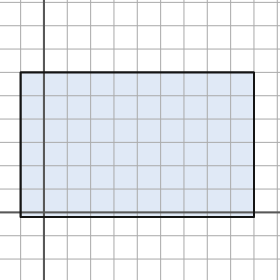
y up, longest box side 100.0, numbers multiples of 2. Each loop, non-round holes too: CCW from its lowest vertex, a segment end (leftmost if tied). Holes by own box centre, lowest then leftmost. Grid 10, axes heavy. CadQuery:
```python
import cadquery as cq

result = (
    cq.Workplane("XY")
    .moveTo(-10.0, -2.0)
    .lineTo(90.0, -2.0)
    .lineTo(90.0, 60.0)
    .lineTo(-10.0, 60.0)
    .close()
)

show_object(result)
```